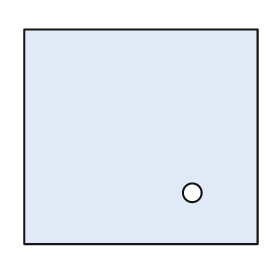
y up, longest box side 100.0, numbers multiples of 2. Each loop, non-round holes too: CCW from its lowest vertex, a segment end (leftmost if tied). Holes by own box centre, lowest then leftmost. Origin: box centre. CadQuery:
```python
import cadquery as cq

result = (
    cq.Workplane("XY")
    .moveTo(-50.0, -46.0)
    .lineTo(50.0, -46.0)
    .lineTo(50.0, 46.0)
    .lineTo(-50.0, 46.0)
    .close()
    .moveTo(22.0, -24.0)
    .circle(4.0)
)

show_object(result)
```